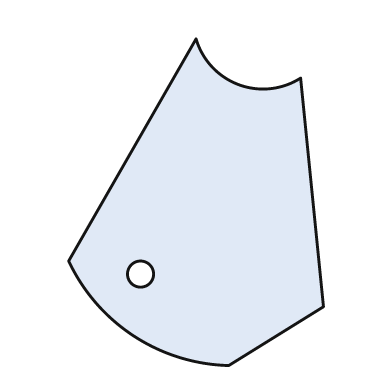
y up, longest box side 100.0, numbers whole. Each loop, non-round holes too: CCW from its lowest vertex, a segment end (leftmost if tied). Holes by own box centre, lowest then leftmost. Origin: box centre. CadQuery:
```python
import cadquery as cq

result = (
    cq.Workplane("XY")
    .moveTo(10.0, -50.0)
    .lineTo(39.0, -32.0)
    .lineTo(32.0, 38.0)
    .threePointArc((13.0, 36.0), (0.0, 50.0))
    .lineTo(-39.0, -18.0)
    .threePointArc((-19.0, -41.0), (10.0, -50.0))
    .close()
    .moveTo(-17.0, -22.0)
    .circle(4.0)
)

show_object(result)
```